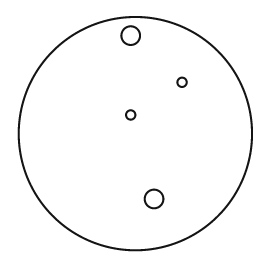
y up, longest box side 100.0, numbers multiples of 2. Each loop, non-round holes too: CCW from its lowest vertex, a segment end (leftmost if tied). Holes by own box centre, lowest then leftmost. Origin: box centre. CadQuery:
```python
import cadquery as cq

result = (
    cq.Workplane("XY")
    .moveTo(0.0, 0.0)
    .circle(50.0)
    .moveTo(8.0, -28.0)
    .circle(4.0)
    .moveTo(-2.0, 8.0)
    .circle(2.0)
    .moveTo(20.0, 22.0)
    .circle(2.0)
    .moveTo(-2.0, 42.0)
    .circle(4.0)
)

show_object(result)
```